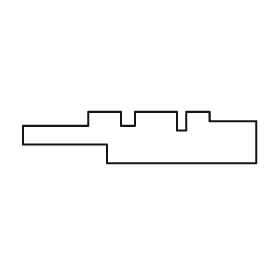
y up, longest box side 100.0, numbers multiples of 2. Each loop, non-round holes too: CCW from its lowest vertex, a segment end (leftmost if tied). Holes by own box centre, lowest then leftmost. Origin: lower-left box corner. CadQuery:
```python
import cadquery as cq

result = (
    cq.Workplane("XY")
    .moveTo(36.0, 0.0)
    .lineTo(100.0, 0.0)
    .lineTo(100.0, 18.0)
    .lineTo(80.0, 18.0)
    .lineTo(80.0, 22.0)
    .lineTo(70.0, 22.0)
    .lineTo(70.0, 14.0)
    .lineTo(66.0, 14.0)
    .lineTo(66.0, 22.0)
    .lineTo(48.0, 22.0)
    .lineTo(48.0, 16.0)
    .lineTo(42.0, 16.0)
    .lineTo(42.0, 22.0)
    .lineTo(28.0, 22.0)
    .lineTo(28.0, 16.0)
    .lineTo(0.0, 16.0)
    .lineTo(0.0, 8.0)
    .lineTo(36.0, 8.0)
    .close()
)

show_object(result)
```